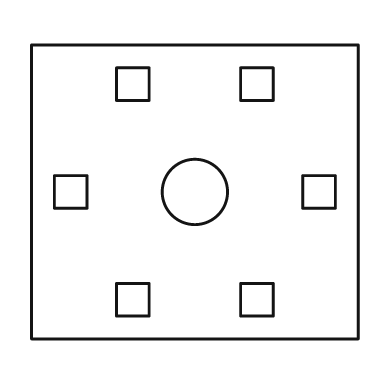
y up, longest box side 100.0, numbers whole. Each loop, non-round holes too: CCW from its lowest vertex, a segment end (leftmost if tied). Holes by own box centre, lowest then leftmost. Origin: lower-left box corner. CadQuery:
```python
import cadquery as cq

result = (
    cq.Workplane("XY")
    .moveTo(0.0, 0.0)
    .lineTo(100.0, 0.0)
    .lineTo(100.0, 90.0)
    .lineTo(0.0, 90.0)
    .close()
    .moveTo(26.0, 7.0)
    .lineTo(36.0, 7.0)
    .lineTo(36.0, 17.0)
    .lineTo(26.0, 17.0)
    .close()
    .moveTo(64.0, 7.0)
    .lineTo(74.0, 7.0)
    .lineTo(74.0, 17.0)
    .lineTo(64.0, 17.0)
    .close()
    .moveTo(7.0, 40.0)
    .lineTo(17.0, 40.0)
    .lineTo(17.0, 50.0)
    .lineTo(7.0, 50.0)
    .close()
    .moveTo(50.0, 45.0)
    .circle(10.0)
    .moveTo(83.0, 40.0)
    .lineTo(93.0, 40.0)
    .lineTo(93.0, 50.0)
    .lineTo(83.0, 50.0)
    .close()
    .moveTo(26.0, 73.0)
    .lineTo(36.0, 73.0)
    .lineTo(36.0, 83.0)
    .lineTo(26.0, 83.0)
    .close()
    .moveTo(64.0, 73.0)
    .lineTo(74.0, 73.0)
    .lineTo(74.0, 83.0)
    .lineTo(64.0, 83.0)
    .close()
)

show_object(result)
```